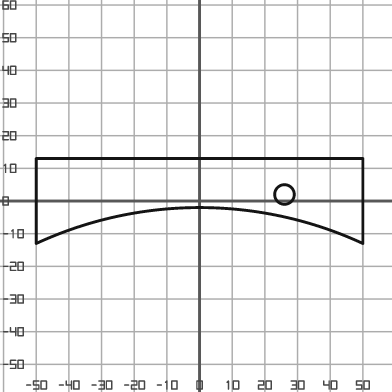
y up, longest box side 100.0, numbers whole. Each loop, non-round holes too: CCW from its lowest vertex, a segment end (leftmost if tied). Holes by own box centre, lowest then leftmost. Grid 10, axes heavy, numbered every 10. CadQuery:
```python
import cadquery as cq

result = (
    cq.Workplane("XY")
    .moveTo(-50.0, -13.0)
    .threePointArc((0.0, -2.0), (50.0, -13.0))
    .lineTo(50.0, 13.0)
    .lineTo(-50.0, 13.0)
    .close()
    .moveTo(26.0, 2.0)
    .circle(3.0)
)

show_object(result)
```